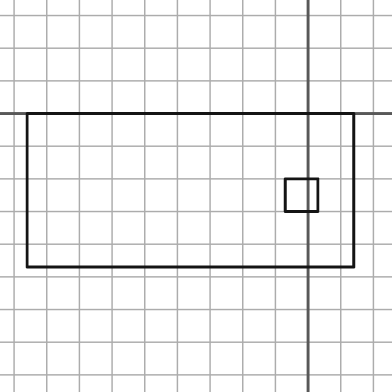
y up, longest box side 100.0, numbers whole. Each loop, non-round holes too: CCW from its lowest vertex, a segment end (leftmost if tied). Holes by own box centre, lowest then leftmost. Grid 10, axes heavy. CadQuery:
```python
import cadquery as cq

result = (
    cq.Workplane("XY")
    .moveTo(-86.0, -47.0)
    .lineTo(14.0, -47.0)
    .lineTo(14.0, 0.0)
    .lineTo(-86.0, 0.0)
    .close()
    .moveTo(-7.0, -30.0)
    .lineTo(3.0, -30.0)
    .lineTo(3.0, -20.0)
    .lineTo(-7.0, -20.0)
    .close()
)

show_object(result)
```